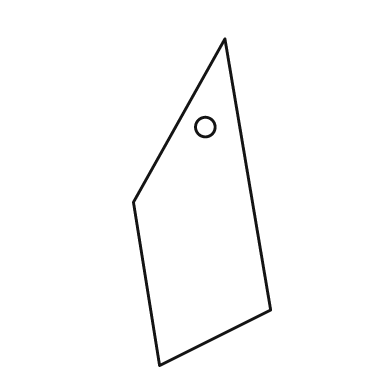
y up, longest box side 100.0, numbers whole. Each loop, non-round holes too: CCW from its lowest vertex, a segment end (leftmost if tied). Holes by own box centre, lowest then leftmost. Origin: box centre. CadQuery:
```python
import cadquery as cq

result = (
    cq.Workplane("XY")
    .moveTo(-13.0, -50.0)
    .lineTo(21.0, -33.0)
    .lineTo(7.0, 50.0)
    .lineTo(-21.0, 0.0)
    .close()
    .moveTo(1.0, 23.0)
    .circle(3.0)
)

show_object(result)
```